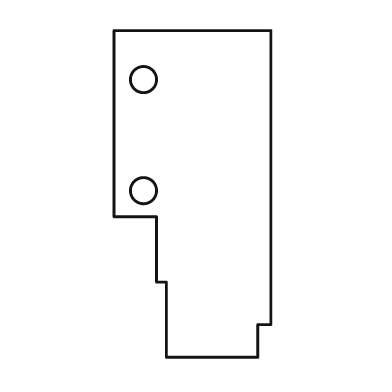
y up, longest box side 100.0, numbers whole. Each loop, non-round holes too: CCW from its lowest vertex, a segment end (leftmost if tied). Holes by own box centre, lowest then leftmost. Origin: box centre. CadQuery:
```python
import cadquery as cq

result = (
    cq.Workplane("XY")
    .moveTo(-8.0, -50.0)
    .lineTo(20.0, -50.0)
    .lineTo(20.0, -40.0)
    .lineTo(24.0, -40.0)
    .lineTo(24.0, 50.0)
    .lineTo(-24.0, 50.0)
    .lineTo(-24.0, -7.0)
    .lineTo(-11.0, -7.0)
    .lineTo(-11.0, -27.0)
    .lineTo(-8.0, -27.0)
    .close()
    .moveTo(-15.0, 1.0)
    .circle(4.0)
    .moveTo(-15.0, 35.0)
    .circle(4.0)
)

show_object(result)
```